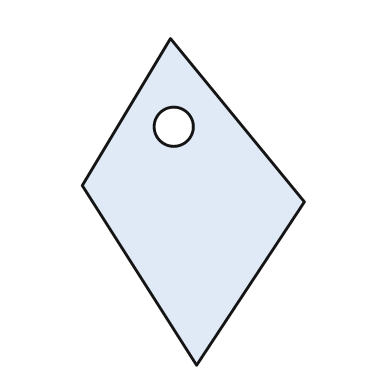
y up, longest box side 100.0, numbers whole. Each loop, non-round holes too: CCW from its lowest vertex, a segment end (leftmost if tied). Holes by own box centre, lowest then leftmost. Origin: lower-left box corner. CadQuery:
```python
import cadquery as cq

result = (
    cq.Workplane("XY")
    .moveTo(35.0, 0.0)
    .lineTo(68.0, 50.0)
    .lineTo(27.0, 100.0)
    .lineTo(0.0, 55.0)
    .close()
    .moveTo(28.0, 73.0)
    .circle(6.0)
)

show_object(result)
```